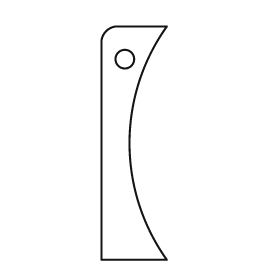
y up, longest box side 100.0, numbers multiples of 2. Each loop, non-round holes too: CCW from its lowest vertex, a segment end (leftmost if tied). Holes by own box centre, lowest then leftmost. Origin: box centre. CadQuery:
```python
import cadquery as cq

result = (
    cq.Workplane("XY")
    .moveTo(-14.0, -50.0)
    .lineTo(14.0, -50.0)
    .threePointArc((-2.0, 0.0), (14.0, 50.0))
    .lineTo(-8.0, 50.0)
    .threePointArc((-12.0, 48.0), (-14.0, 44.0))
    .close()
    .moveTo(-4.0, 36.0)
    .circle(4.0)
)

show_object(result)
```